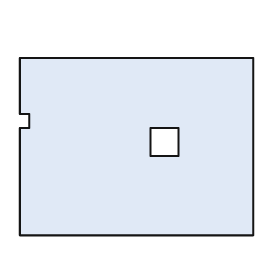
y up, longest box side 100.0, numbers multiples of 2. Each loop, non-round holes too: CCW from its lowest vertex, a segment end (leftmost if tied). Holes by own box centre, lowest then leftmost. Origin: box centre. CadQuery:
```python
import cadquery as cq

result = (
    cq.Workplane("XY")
    .moveTo(-50.0, -38.0)
    .lineTo(50.0, -38.0)
    .lineTo(50.0, 38.0)
    .lineTo(-50.0, 38.0)
    .lineTo(-50.0, 14.0)
    .lineTo(-46.0, 14.0)
    .lineTo(-46.0, 8.0)
    .lineTo(-50.0, 8.0)
    .close()
    .moveTo(6.0, -4.0)
    .lineTo(18.0, -4.0)
    .lineTo(18.0, 8.0)
    .lineTo(6.0, 8.0)
    .close()
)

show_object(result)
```